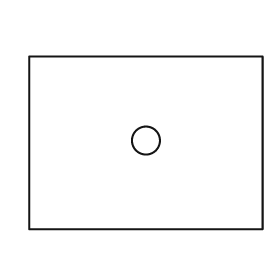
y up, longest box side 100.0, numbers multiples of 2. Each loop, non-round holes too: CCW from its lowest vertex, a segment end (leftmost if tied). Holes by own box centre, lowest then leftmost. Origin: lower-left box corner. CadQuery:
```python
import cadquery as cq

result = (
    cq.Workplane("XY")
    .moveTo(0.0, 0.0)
    .lineTo(100.0, 0.0)
    .lineTo(100.0, 74.0)
    .lineTo(0.0, 74.0)
    .close()
    .moveTo(50.0, 38.0)
    .circle(6.0)
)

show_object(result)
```